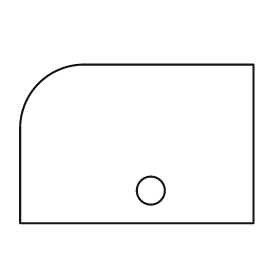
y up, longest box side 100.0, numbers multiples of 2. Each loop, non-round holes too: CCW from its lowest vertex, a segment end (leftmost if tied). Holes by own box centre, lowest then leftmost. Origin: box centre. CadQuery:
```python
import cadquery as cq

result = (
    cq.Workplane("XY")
    .moveTo(-50.0, -34.0)
    .lineTo(50.0, -34.0)
    .lineTo(50.0, 34.0)
    .lineTo(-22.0, 34.0)
    .threePointArc((-42.0, 26.0), (-50.0, 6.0))
    .close()
    .moveTo(6.0, -20.0)
    .circle(6.0)
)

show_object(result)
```